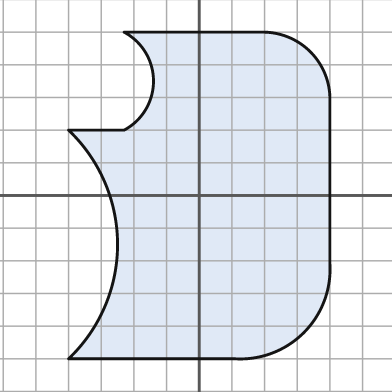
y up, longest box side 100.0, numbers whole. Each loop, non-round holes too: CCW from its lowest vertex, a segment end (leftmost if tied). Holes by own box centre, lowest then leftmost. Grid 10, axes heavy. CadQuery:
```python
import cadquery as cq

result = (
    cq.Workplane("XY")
    .moveTo(-40.0, -50.0)
    .lineTo(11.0, -50.0)
    .threePointArc((32.0, -42.0), (40.0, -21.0))
    .lineTo(40.0, 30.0)
    .threePointArc((34.0, 44.0), (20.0, 50.0))
    .lineTo(-23.0, 50.0)
    .threePointArc((-14.0, 35.0), (-23.0, 20.0))
    .lineTo(-40.0, 20.0)
    .threePointArc((-25.0, -15.0), (-40.0, -50.0))
    .close()
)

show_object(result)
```